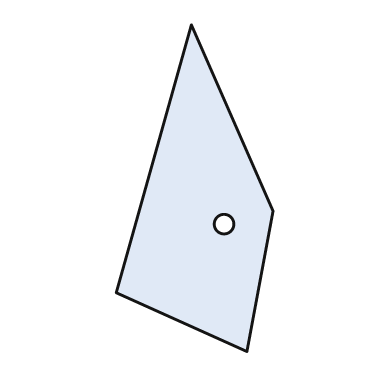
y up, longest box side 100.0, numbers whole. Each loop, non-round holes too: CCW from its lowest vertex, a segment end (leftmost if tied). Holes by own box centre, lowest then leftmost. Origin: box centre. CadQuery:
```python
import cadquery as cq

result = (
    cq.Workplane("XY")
    .moveTo(16.0, -50.0)
    .lineTo(24.0, -7.0)
    .lineTo(-1.0, 50.0)
    .lineTo(-24.0, -32.0)
    .close()
    .moveTo(9.0, -11.0)
    .circle(3.0)
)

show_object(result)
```